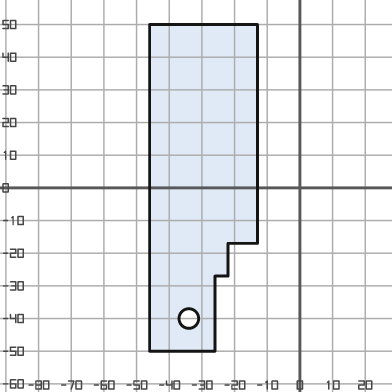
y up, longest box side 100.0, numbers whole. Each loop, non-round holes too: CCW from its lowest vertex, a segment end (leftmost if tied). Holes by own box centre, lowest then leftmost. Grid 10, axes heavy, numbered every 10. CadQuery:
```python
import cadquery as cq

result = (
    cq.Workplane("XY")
    .moveTo(-46.0, -50.0)
    .lineTo(-26.0, -50.0)
    .lineTo(-26.0, -27.0)
    .lineTo(-22.0, -27.0)
    .lineTo(-22.0, -17.0)
    .lineTo(-13.0, -17.0)
    .lineTo(-13.0, 50.0)
    .lineTo(-46.0, 50.0)
    .close()
    .moveTo(-34.0, -40.0)
    .circle(3.0)
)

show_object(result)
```